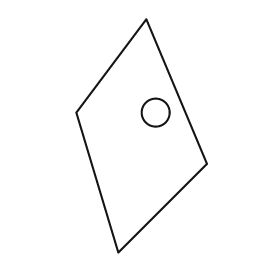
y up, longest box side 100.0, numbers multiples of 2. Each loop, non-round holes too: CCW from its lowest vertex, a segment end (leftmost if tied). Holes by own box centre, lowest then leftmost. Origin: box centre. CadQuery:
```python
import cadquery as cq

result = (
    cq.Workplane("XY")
    .moveTo(-10.0, -50.0)
    .lineTo(28.0, -12.0)
    .lineTo(2.0, 50.0)
    .lineTo(-28.0, 10.0)
    .close()
    .moveTo(6.0, 10.0)
    .circle(6.0)
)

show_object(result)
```